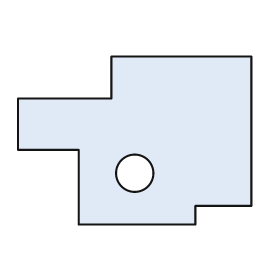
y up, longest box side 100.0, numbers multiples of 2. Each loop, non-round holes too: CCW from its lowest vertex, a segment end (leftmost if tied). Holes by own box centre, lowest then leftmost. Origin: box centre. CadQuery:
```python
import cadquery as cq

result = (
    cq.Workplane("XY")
    .moveTo(-24.0, -36.0)
    .lineTo(26.0, -36.0)
    .lineTo(26.0, -28.0)
    .lineTo(50.0, -28.0)
    .lineTo(50.0, 36.0)
    .lineTo(-10.0, 36.0)
    .lineTo(-10.0, 18.0)
    .lineTo(-50.0, 18.0)
    .lineTo(-50.0, -4.0)
    .lineTo(-24.0, -4.0)
    .close()
    .moveTo(0.0, -14.0)
    .circle(8.0)
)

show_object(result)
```